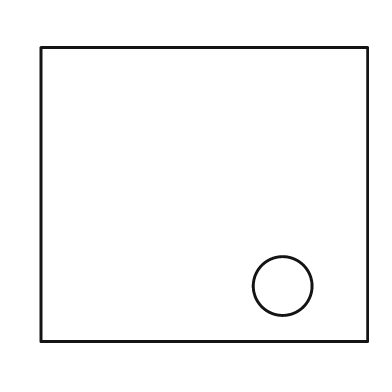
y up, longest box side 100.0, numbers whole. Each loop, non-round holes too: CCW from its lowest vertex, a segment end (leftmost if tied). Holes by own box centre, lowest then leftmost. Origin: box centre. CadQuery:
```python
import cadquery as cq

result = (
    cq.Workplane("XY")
    .moveTo(-50.0, -45.0)
    .lineTo(50.0, -45.0)
    .lineTo(50.0, 45.0)
    .lineTo(-50.0, 45.0)
    .close()
    .moveTo(24.0, -28.0)
    .circle(9.0)
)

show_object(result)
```